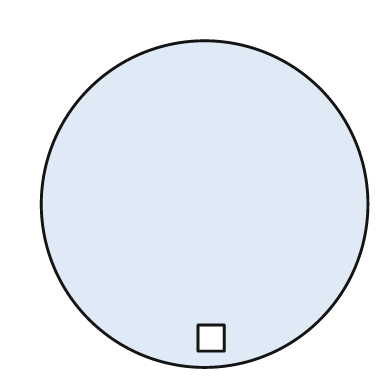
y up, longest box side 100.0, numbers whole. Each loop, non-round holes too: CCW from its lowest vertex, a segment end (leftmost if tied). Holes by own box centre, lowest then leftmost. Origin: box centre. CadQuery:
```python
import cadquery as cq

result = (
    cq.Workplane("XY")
    .moveTo(0.0, 0.0)
    .circle(50.0)
    .moveTo(-2.0, -45.0)
    .lineTo(6.0, -45.0)
    .lineTo(6.0, -37.0)
    .lineTo(-2.0, -37.0)
    .close()
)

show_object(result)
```